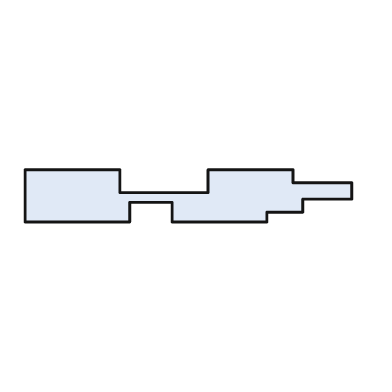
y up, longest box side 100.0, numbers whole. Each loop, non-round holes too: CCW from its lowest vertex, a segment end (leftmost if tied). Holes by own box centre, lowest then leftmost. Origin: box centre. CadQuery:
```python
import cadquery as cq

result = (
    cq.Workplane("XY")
    .moveTo(-50.0, -8.0)
    .lineTo(-18.0, -8.0)
    .lineTo(-18.0, -2.0)
    .lineTo(-5.0, -2.0)
    .lineTo(-5.0, -8.0)
    .lineTo(24.0, -8.0)
    .lineTo(24.0, -5.0)
    .lineTo(35.0, -5.0)
    .lineTo(35.0, -1.0)
    .lineTo(50.0, -1.0)
    .lineTo(50.0, 4.0)
    .lineTo(32.0, 4.0)
    .lineTo(32.0, 8.0)
    .lineTo(6.0, 8.0)
    .lineTo(6.0, 1.0)
    .lineTo(-21.0, 1.0)
    .lineTo(-21.0, 8.0)
    .lineTo(-50.0, 8.0)
    .close()
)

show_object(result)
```